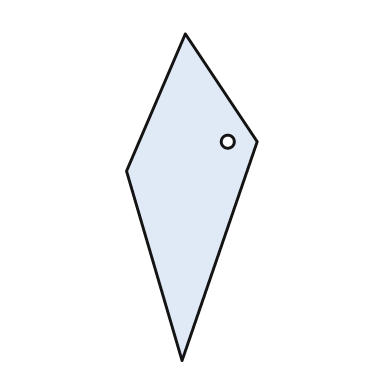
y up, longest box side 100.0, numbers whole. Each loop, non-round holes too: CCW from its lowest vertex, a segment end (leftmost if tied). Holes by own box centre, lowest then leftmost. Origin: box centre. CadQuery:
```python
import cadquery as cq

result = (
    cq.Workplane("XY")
    .moveTo(-3.0, -50.0)
    .lineTo(20.0, 17.0)
    .lineTo(-2.0, 50.0)
    .lineTo(-20.0, 8.0)
    .close()
    .moveTo(11.0, 17.0)
    .circle(2.0)
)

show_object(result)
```